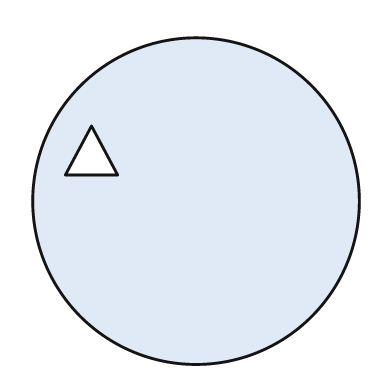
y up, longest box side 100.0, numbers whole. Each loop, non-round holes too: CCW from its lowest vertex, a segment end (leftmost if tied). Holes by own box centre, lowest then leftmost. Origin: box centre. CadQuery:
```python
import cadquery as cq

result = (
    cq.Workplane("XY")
    .moveTo(0.0, 0.0)
    .circle(50.0)
    .moveTo(-40.0, 8.0)
    .lineTo(-24.0, 8.0)
    .lineTo(-32.0, 23.0)
    .close()
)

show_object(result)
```